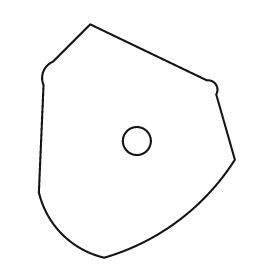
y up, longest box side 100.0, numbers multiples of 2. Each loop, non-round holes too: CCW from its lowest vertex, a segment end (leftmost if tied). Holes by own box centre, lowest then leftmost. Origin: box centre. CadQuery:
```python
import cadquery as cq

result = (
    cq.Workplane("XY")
    .moveTo(-14.0, -50.0)
    .threePointArc((18.0, -34.0), (42.0, -8.0))
    .lineTo(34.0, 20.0)
    .threePointArc((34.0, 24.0), (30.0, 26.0))
    .lineTo(-20.0, 50.0)
    .lineTo(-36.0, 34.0)
    .threePointArc((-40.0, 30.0), (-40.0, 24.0))
    .lineTo(-42.0, -22.0)
    .threePointArc((-32.0, -40.0), (-14.0, -50.0))
    .close()
    .moveTo(0.0, 0.0)
    .circle(6.0)
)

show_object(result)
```